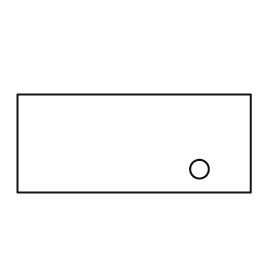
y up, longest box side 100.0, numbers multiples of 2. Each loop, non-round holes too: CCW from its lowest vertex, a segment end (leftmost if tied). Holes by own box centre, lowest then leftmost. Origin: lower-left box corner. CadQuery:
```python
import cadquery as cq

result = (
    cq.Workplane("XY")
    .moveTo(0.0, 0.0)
    .lineTo(100.0, 0.0)
    .lineTo(100.0, 42.0)
    .lineTo(0.0, 42.0)
    .close()
    .moveTo(78.0, 10.0)
    .circle(4.0)
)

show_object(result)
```